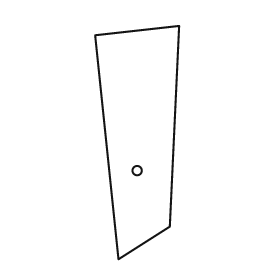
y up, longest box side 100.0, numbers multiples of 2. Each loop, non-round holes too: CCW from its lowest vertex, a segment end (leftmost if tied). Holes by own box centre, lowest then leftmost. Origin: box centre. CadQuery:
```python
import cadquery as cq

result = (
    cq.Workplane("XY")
    .moveTo(-8.0, -50.0)
    .lineTo(14.0, -36.0)
    .lineTo(18.0, 50.0)
    .lineTo(-18.0, 46.0)
    .close()
    .moveTo(0.0, -12.0)
    .circle(2.0)
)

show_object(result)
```